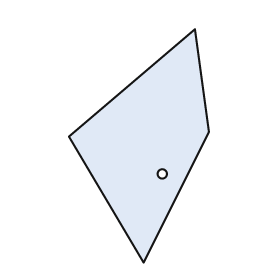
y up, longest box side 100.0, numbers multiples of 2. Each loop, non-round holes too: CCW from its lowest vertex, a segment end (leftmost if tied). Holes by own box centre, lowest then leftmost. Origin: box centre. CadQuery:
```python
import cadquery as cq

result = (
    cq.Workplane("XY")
    .moveTo(2.0, -50.0)
    .lineTo(30.0, 6.0)
    .lineTo(24.0, 50.0)
    .lineTo(-30.0, 4.0)
    .close()
    .moveTo(10.0, -12.0)
    .circle(2.0)
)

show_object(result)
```